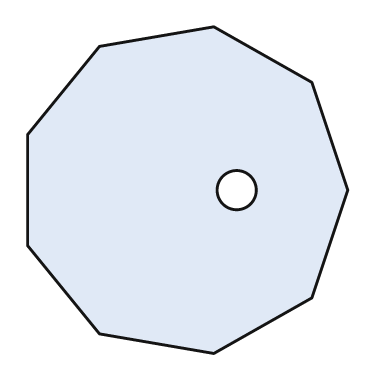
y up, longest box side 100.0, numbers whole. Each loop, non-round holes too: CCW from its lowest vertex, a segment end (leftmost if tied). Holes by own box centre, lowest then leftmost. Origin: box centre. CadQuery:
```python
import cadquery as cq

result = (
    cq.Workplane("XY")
    .moveTo(8.0, -50.0)
    .lineTo(38.0, -33.0)
    .lineTo(49.0, 0.0)
    .lineTo(38.0, 33.0)
    .lineTo(8.0, 50.0)
    .lineTo(-27.0, 44.0)
    .lineTo(-49.0, 17.0)
    .lineTo(-49.0, -17.0)
    .lineTo(-27.0, -44.0)
    .close()
    .moveTo(15.0, 0.0)
    .circle(6.0)
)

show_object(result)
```